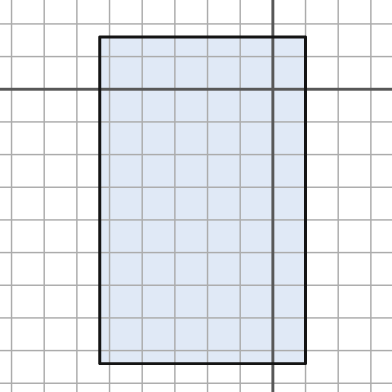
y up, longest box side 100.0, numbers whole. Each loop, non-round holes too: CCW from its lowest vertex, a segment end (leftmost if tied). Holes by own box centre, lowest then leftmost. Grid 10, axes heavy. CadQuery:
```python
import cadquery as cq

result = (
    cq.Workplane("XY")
    .moveTo(-53.0, -84.0)
    .lineTo(10.0, -84.0)
    .lineTo(10.0, 16.0)
    .lineTo(-53.0, 16.0)
    .close()
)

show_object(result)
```